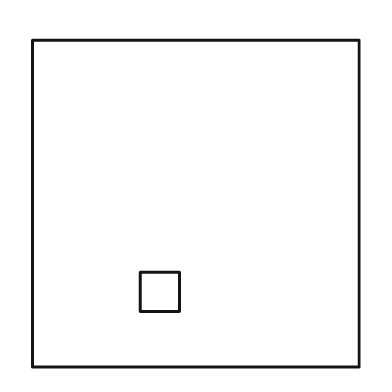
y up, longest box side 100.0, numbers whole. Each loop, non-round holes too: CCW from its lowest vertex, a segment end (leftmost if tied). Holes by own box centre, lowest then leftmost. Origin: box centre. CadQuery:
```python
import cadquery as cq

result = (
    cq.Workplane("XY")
    .moveTo(-50.0, -50.0)
    .lineTo(50.0, -50.0)
    .lineTo(50.0, 50.0)
    .lineTo(-50.0, 50.0)
    .close()
    .moveTo(-17.0, -33.0)
    .lineTo(-5.0, -33.0)
    .lineTo(-5.0, -21.0)
    .lineTo(-17.0, -21.0)
    .close()
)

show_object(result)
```